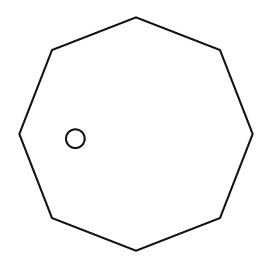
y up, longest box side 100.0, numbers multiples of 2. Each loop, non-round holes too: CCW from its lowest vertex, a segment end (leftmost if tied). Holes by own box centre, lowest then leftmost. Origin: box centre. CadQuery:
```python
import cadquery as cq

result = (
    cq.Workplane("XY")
    .moveTo(0.0, -50.0)
    .lineTo(36.0, -36.0)
    .lineTo(50.0, 0.0)
    .lineTo(36.0, 36.0)
    .lineTo(0.0, 50.0)
    .lineTo(-36.0, 36.0)
    .lineTo(-50.0, 0.0)
    .lineTo(-36.0, -36.0)
    .close()
    .moveTo(-26.0, -2.0)
    .circle(4.0)
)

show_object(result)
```